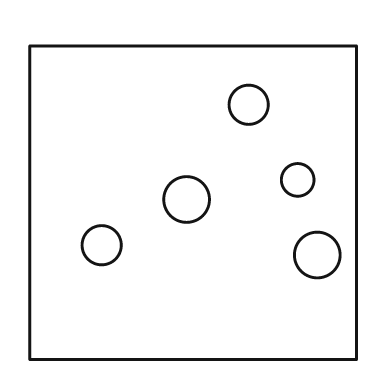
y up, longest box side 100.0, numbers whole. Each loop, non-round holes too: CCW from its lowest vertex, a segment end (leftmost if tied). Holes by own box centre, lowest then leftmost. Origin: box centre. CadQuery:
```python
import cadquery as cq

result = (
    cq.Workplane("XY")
    .moveTo(-50.0, -48.0)
    .lineTo(50.0, -48.0)
    .lineTo(50.0, 48.0)
    .lineTo(-50.0, 48.0)
    .close()
    .moveTo(38.0, -16.0)
    .circle(7.0)
    .moveTo(-28.0, -13.0)
    .circle(6.0)
    .moveTo(-2.0, 1.0)
    .circle(7.0)
    .moveTo(32.0, 7.0)
    .circle(5.0)
    .moveTo(17.0, 30.0)
    .circle(6.0)
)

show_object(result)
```